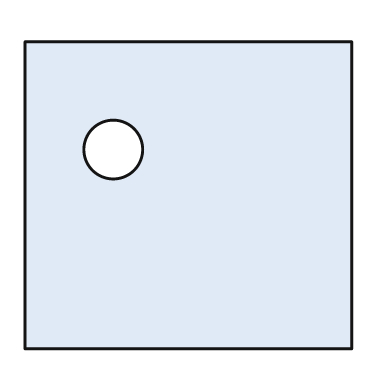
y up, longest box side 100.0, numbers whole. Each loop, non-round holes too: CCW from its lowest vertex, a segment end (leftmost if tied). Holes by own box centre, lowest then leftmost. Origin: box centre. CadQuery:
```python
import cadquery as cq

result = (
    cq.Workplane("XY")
    .moveTo(-50.0, -47.0)
    .lineTo(50.0, -47.0)
    .lineTo(50.0, 47.0)
    .lineTo(-50.0, 47.0)
    .close()
    .moveTo(-23.0, 14.0)
    .circle(9.0)
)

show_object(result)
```